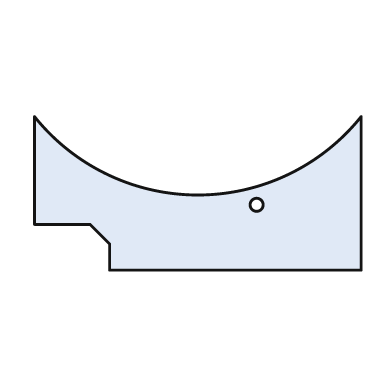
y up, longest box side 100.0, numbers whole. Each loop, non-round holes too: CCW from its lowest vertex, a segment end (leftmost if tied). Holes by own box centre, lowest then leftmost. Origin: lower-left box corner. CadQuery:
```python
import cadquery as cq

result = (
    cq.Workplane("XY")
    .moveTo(23.0, 0.0)
    .lineTo(100.0, 0.0)
    .lineTo(100.0, 47.0)
    .threePointArc((50.0, 23.0), (0.0, 47.0))
    .lineTo(0.0, 14.0)
    .lineTo(17.0, 14.0)
    .lineTo(23.0, 8.0)
    .close()
    .moveTo(68.0, 20.0)
    .circle(2.0)
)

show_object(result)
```